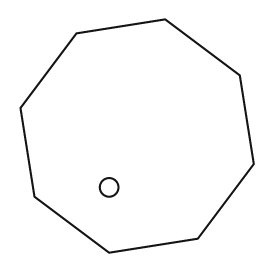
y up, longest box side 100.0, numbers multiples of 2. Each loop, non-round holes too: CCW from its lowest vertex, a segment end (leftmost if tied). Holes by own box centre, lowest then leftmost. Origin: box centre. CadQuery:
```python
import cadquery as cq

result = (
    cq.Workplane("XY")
    .moveTo(-12.0, -50.0)
    .lineTo(26.0, -44.0)
    .lineTo(50.0, -12.0)
    .lineTo(44.0, 26.0)
    .lineTo(12.0, 50.0)
    .lineTo(-26.0, 44.0)
    .lineTo(-50.0, 12.0)
    .lineTo(-44.0, -26.0)
    .close()
    .moveTo(-12.0, -22.0)
    .circle(4.0)
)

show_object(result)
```